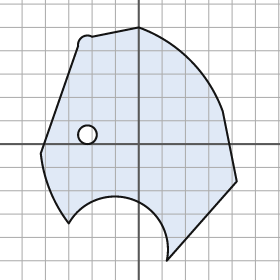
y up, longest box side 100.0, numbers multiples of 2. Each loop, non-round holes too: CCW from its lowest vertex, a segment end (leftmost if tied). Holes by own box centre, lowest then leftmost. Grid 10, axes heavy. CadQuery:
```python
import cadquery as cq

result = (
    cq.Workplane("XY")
    .moveTo(12.0, -50.0)
    .lineTo(42.0, -16.0)
    .lineTo(36.0, 14.0)
    .threePointArc((22.0, 36.0), (0.0, 50.0))
    .lineTo(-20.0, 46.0)
    .threePointArc((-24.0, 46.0), (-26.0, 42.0))
    .lineTo(-42.0, -4.0)
    .threePointArc((-38.0, -20.0), (-30.0, -34.0))
    .threePointArc((-2.0, -24.0), (12.0, -50.0))
    .close()
    .moveTo(-22.0, 4.0)
    .circle(4.0)
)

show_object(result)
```